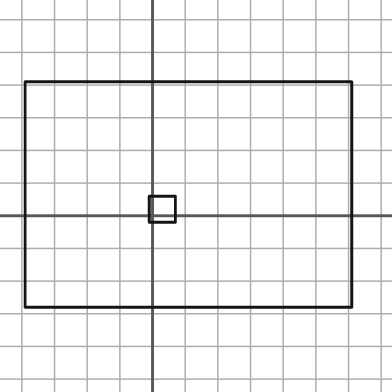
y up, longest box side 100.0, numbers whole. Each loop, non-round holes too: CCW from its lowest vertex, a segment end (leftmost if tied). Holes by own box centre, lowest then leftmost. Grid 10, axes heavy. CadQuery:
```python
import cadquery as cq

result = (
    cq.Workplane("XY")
    .moveTo(-39.0, -28.0)
    .lineTo(61.0, -28.0)
    .lineTo(61.0, 41.0)
    .lineTo(-39.0, 41.0)
    .close()
    .moveTo(-1.0, -2.0)
    .lineTo(7.0, -2.0)
    .lineTo(7.0, 6.0)
    .lineTo(-1.0, 6.0)
    .close()
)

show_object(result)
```